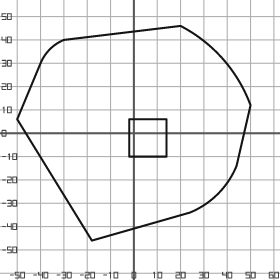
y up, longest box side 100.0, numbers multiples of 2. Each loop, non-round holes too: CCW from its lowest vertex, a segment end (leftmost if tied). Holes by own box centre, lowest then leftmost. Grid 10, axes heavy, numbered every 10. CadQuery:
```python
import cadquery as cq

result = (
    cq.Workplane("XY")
    .moveTo(-18.0, -46.0)
    .lineTo(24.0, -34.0)
    .threePointArc((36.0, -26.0), (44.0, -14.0))
    .lineTo(50.0, 12.0)
    .threePointArc((38.0, 32.0), (20.0, 46.0))
    .lineTo(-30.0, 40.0)
    .threePointArc((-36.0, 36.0), (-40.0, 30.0))
    .lineTo(-50.0, 6.0)
    .close()
    .moveTo(-2.0, -10.0)
    .lineTo(14.0, -10.0)
    .lineTo(14.0, 6.0)
    .lineTo(-2.0, 6.0)
    .close()
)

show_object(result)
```